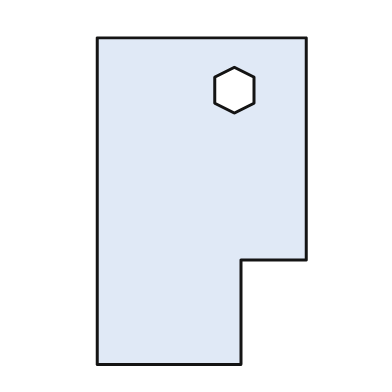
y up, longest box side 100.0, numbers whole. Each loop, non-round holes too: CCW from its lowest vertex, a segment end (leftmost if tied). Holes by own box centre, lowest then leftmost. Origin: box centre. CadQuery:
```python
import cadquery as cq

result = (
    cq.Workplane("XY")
    .moveTo(-32.0, -50.0)
    .lineTo(12.0, -50.0)
    .lineTo(12.0, -18.0)
    .lineTo(32.0, -18.0)
    .lineTo(32.0, 50.0)
    .lineTo(-32.0, 50.0)
    .close()
    .moveTo(10.0, 27.0)
    .lineTo(16.0, 30.0)
    .lineTo(16.0, 38.0)
    .lineTo(10.0, 41.0)
    .lineTo(4.0, 38.0)
    .lineTo(4.0, 30.0)
    .close()
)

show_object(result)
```